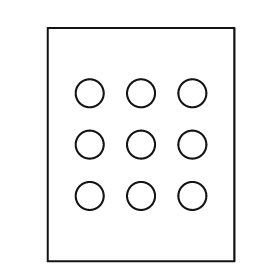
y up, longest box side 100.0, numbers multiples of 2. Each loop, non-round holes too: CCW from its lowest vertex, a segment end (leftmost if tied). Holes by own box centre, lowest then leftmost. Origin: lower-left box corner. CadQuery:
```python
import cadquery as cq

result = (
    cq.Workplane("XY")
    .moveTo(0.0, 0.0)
    .lineTo(80.0, 0.0)
    .lineTo(80.0, 100.0)
    .lineTo(0.0, 100.0)
    .close()
    .moveTo(18.0, 28.0)
    .circle(6.0)
    .moveTo(40.0, 28.0)
    .circle(6.0)
    .moveTo(62.0, 28.0)
    .circle(6.0)
    .moveTo(18.0, 50.0)
    .circle(6.0)
    .moveTo(40.0, 50.0)
    .circle(6.0)
    .moveTo(62.0, 50.0)
    .circle(6.0)
    .moveTo(18.0, 72.0)
    .circle(6.0)
    .moveTo(40.0, 72.0)
    .circle(6.0)
    .moveTo(62.0, 72.0)
    .circle(6.0)
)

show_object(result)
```